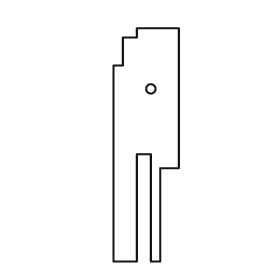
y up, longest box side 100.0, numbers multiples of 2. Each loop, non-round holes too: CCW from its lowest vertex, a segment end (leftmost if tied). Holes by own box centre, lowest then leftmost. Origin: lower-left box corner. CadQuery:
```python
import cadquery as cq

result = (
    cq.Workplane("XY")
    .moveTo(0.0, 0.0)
    .lineTo(10.0, 0.0)
    .lineTo(10.0, 46.0)
    .lineTo(16.0, 46.0)
    .lineTo(16.0, 0.0)
    .lineTo(20.0, 0.0)
    .lineTo(20.0, 40.0)
    .lineTo(28.0, 40.0)
    .lineTo(28.0, 100.0)
    .lineTo(10.0, 100.0)
    .lineTo(10.0, 96.0)
    .lineTo(4.0, 96.0)
    .lineTo(4.0, 84.0)
    .lineTo(0.0, 84.0)
    .close()
    .moveTo(16.0, 74.0)
    .circle(2.0)
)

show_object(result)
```